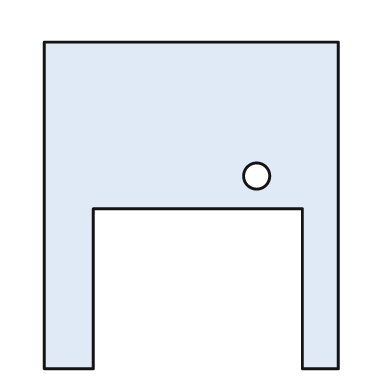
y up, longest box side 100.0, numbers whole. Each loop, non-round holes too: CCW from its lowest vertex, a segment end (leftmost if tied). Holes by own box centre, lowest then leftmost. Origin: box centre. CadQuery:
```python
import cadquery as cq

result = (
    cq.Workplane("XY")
    .moveTo(-45.0, -50.0)
    .lineTo(-30.0, -50.0)
    .lineTo(-30.0, -1.0)
    .lineTo(34.0, -1.0)
    .lineTo(34.0, -50.0)
    .lineTo(45.0, -50.0)
    .lineTo(45.0, 50.0)
    .lineTo(-45.0, 50.0)
    .close()
    .moveTo(20.0, 9.0)
    .circle(4.0)
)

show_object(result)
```